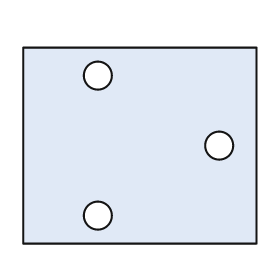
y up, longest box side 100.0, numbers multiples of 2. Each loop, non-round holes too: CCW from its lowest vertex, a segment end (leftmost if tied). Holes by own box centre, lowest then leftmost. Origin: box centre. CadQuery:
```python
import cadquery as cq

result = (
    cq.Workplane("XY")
    .moveTo(-50.0, -42.0)
    .lineTo(50.0, -42.0)
    .lineTo(50.0, 42.0)
    .lineTo(-50.0, 42.0)
    .close()
    .moveTo(-18.0, -30.0)
    .circle(6.0)
    .moveTo(34.0, 0.0)
    .circle(6.0)
    .moveTo(-18.0, 30.0)
    .circle(6.0)
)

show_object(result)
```